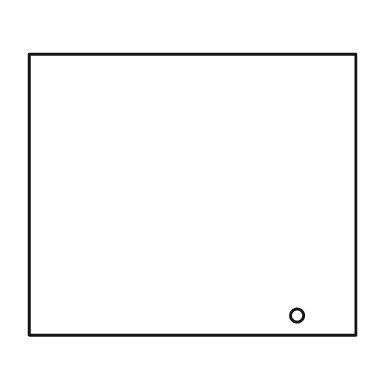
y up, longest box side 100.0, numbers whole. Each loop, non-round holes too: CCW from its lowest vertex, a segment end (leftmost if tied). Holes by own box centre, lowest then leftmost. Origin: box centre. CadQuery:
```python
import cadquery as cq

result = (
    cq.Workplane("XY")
    .moveTo(-50.0, -43.0)
    .lineTo(50.0, -43.0)
    .lineTo(50.0, 43.0)
    .lineTo(-50.0, 43.0)
    .close()
    .moveTo(32.0, -37.0)
    .circle(2.0)
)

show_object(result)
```